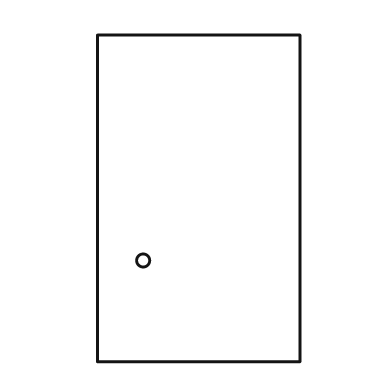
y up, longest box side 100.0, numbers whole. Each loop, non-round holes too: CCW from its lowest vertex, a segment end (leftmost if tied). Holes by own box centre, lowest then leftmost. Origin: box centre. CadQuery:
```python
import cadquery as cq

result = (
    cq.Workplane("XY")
    .moveTo(-31.0, -50.0)
    .lineTo(31.0, -50.0)
    .lineTo(31.0, 50.0)
    .lineTo(-31.0, 50.0)
    .close()
    .moveTo(-17.0, -19.0)
    .circle(2.0)
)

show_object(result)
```